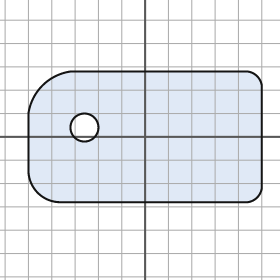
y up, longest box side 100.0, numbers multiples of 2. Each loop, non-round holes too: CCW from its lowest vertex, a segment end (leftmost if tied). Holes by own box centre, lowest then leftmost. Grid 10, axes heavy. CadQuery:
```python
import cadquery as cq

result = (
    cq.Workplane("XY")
    .moveTo(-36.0, -28.0)
    .lineTo(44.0, -28.0)
    .threePointArc((48.0, -26.0), (50.0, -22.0))
    .lineTo(50.0, 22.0)
    .threePointArc((48.0, 26.0), (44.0, 28.0))
    .lineTo(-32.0, 28.0)
    .threePointArc((-44.0, 22.0), (-50.0, 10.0))
    .lineTo(-50.0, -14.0)
    .threePointArc((-46.0, -24.0), (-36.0, -28.0))
    .close()
    .moveTo(-26.0, 4.0)
    .circle(6.0)
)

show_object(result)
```